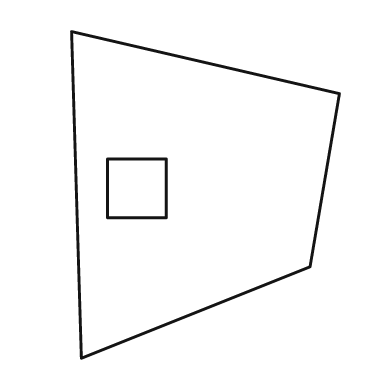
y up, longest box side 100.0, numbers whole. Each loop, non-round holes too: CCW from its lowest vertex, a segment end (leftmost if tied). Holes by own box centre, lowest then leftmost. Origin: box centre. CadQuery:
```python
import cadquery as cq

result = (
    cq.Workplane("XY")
    .moveTo(-38.0, -50.0)
    .lineTo(32.0, -22.0)
    .lineTo(41.0, 31.0)
    .lineTo(-41.0, 50.0)
    .close()
    .moveTo(-30.0, -7.0)
    .lineTo(-12.0, -7.0)
    .lineTo(-12.0, 11.0)
    .lineTo(-30.0, 11.0)
    .close()
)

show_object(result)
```